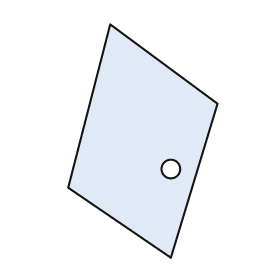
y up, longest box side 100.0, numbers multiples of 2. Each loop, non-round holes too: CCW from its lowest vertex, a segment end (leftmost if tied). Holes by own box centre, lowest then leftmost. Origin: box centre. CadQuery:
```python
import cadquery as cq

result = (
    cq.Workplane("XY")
    .moveTo(12.0, -50.0)
    .lineTo(32.0, 16.0)
    .lineTo(-14.0, 50.0)
    .lineTo(-32.0, -20.0)
    .close()
    .moveTo(12.0, -12.0)
    .circle(4.0)
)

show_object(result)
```